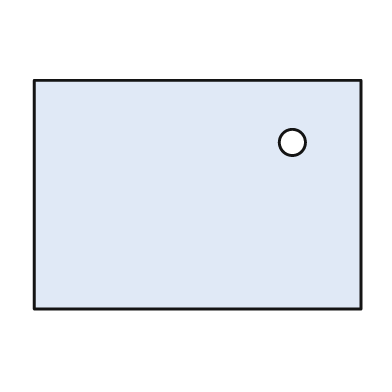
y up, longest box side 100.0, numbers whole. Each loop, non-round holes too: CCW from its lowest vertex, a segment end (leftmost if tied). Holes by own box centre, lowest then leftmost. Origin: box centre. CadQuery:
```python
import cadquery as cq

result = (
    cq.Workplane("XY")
    .moveTo(-50.0, -35.0)
    .lineTo(50.0, -35.0)
    .lineTo(50.0, 35.0)
    .lineTo(-50.0, 35.0)
    .close()
    .moveTo(29.0, 16.0)
    .circle(4.0)
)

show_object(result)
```